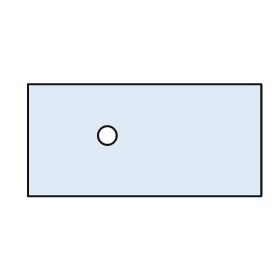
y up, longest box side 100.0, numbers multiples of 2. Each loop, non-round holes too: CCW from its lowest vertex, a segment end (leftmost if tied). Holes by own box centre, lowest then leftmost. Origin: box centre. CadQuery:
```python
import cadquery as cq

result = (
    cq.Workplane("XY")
    .moveTo(-50.0, -24.0)
    .lineTo(50.0, -24.0)
    .lineTo(50.0, 24.0)
    .lineTo(-50.0, 24.0)
    .close()
    .moveTo(-16.0, 2.0)
    .circle(4.0)
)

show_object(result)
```